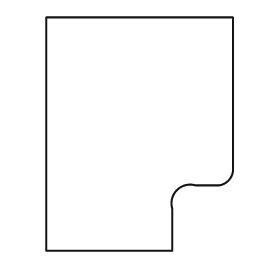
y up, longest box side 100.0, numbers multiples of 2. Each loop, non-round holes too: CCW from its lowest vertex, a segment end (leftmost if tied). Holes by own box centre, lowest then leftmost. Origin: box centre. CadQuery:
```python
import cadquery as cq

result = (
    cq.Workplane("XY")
    .moveTo(-40.0, -50.0)
    .lineTo(14.0, -50.0)
    .lineTo(14.0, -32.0)
    .threePointArc((16.0, -24.0), (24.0, -22.0))
    .lineTo(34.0, -22.0)
    .threePointArc((38.0, -20.0), (40.0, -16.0))
    .lineTo(40.0, 50.0)
    .lineTo(-40.0, 50.0)
    .close()
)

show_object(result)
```